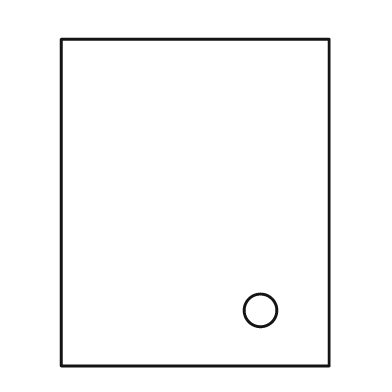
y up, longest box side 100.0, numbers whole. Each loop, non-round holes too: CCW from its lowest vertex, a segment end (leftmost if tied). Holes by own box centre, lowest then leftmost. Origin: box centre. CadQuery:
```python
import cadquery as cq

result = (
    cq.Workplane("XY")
    .moveTo(-41.0, -50.0)
    .lineTo(41.0, -50.0)
    .lineTo(41.0, 50.0)
    .lineTo(-41.0, 50.0)
    .close()
    .moveTo(20.0, -33.0)
    .circle(5.0)
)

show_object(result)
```